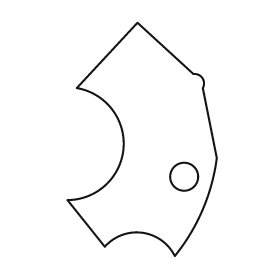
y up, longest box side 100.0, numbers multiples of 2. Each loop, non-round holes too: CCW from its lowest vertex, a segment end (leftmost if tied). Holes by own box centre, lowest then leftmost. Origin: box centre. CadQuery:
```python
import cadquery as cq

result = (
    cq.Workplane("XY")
    .moveTo(14.0, -50.0)
    .threePointArc((26.0, -30.0), (32.0, -8.0))
    .lineTo(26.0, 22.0)
    .threePointArc((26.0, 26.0), (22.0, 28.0))
    .lineTo(-2.0, 50.0)
    .lineTo(-28.0, 22.0)
    .threePointArc((-8.0, -4.0), (-32.0, -26.0))
    .lineTo(-16.0, -46.0)
    .threePointArc((0.0, -40.0), (14.0, -50.0))
    .close()
    .moveTo(18.0, -16.0)
    .circle(6.0)
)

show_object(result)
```